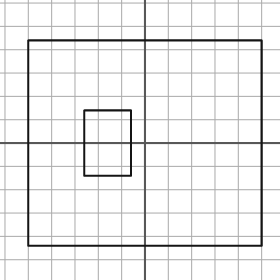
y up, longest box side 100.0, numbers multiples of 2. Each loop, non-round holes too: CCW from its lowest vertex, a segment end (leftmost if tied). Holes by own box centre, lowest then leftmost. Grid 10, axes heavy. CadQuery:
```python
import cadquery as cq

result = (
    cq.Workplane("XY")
    .moveTo(-50.0, -44.0)
    .lineTo(50.0, -44.0)
    .lineTo(50.0, 44.0)
    .lineTo(-50.0, 44.0)
    .close()
    .moveTo(-26.0, -14.0)
    .lineTo(-6.0, -14.0)
    .lineTo(-6.0, 14.0)
    .lineTo(-26.0, 14.0)
    .close()
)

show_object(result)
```